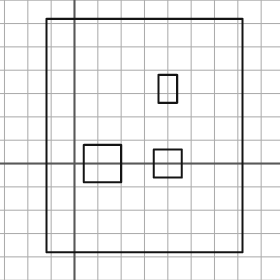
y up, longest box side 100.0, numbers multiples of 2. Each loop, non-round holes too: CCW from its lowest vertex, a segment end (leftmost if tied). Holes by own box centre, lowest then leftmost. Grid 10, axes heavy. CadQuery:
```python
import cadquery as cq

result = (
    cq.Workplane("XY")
    .moveTo(-12.0, -38.0)
    .lineTo(72.0, -38.0)
    .lineTo(72.0, 62.0)
    .lineTo(-12.0, 62.0)
    .close()
    .moveTo(4.0, -8.0)
    .lineTo(20.0, -8.0)
    .lineTo(20.0, 8.0)
    .lineTo(4.0, 8.0)
    .close()
    .moveTo(34.0, -6.0)
    .lineTo(46.0, -6.0)
    .lineTo(46.0, 6.0)
    .lineTo(34.0, 6.0)
    .close()
    .moveTo(36.0, 26.0)
    .lineTo(44.0, 26.0)
    .lineTo(44.0, 38.0)
    .lineTo(36.0, 38.0)
    .close()
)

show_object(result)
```